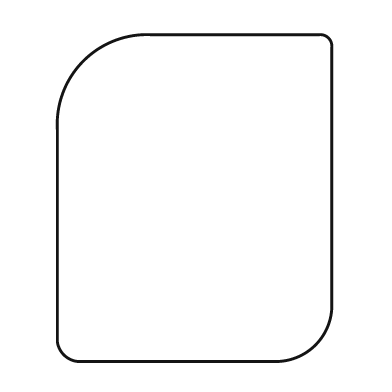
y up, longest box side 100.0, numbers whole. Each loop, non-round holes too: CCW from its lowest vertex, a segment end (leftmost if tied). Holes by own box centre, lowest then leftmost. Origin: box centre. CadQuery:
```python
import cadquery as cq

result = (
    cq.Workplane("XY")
    .moveTo(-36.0, -50.0)
    .lineTo(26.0, -50.0)
    .threePointArc((37.0, -45.0), (42.0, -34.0))
    .lineTo(42.0, 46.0)
    .threePointArc((41.0, 49.0), (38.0, 50.0))
    .lineTo(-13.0, 50.0)
    .threePointArc((-34.0, 42.0), (-42.0, 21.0))
    .lineTo(-42.0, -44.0)
    .threePointArc((-40.0, -48.0), (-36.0, -50.0))
    .close()
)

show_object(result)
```